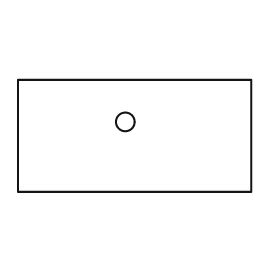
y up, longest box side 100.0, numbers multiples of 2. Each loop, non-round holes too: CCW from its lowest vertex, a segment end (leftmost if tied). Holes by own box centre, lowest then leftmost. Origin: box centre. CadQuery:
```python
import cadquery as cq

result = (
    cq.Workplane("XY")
    .moveTo(-50.0, -24.0)
    .lineTo(50.0, -24.0)
    .lineTo(50.0, 24.0)
    .lineTo(-50.0, 24.0)
    .close()
    .moveTo(-4.0, 6.0)
    .circle(4.0)
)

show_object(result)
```